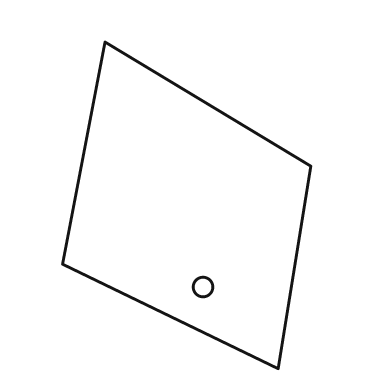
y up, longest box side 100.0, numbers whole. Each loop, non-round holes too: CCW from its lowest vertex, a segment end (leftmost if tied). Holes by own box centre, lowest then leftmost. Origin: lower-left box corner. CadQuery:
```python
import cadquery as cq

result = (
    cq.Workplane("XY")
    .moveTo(66.0, 0.0)
    .lineTo(76.0, 62.0)
    .lineTo(13.0, 100.0)
    .lineTo(0.0, 32.0)
    .close()
    .moveTo(43.0, 25.0)
    .circle(3.0)
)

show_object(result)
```